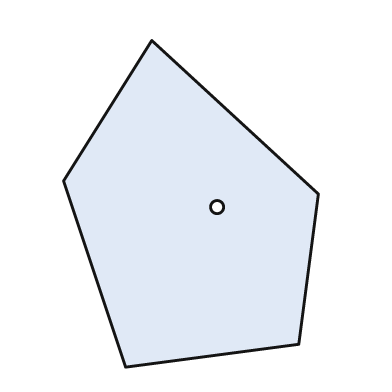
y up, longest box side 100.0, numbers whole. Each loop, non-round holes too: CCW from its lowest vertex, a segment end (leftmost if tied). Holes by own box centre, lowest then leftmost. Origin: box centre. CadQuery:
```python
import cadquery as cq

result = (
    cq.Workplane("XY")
    .moveTo(-20.0, -50.0)
    .lineTo(33.0, -43.0)
    .lineTo(39.0, 3.0)
    .lineTo(-12.0, 50.0)
    .lineTo(-39.0, 7.0)
    .close()
    .moveTo(8.0, -1.0)
    .circle(2.0)
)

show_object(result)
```